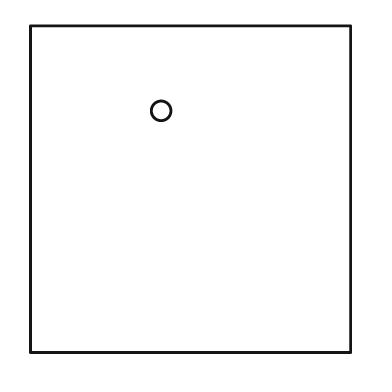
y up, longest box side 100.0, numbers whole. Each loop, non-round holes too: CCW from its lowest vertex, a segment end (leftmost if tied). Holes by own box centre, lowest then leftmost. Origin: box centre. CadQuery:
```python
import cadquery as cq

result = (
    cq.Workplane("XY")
    .moveTo(-49.0, -50.0)
    .lineTo(49.0, -50.0)
    .lineTo(49.0, 50.0)
    .lineTo(-49.0, 50.0)
    .close()
    .moveTo(-9.0, 24.0)
    .circle(3.0)
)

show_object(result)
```